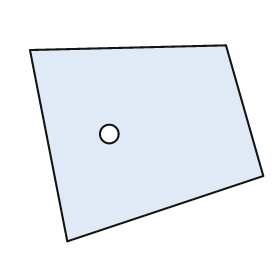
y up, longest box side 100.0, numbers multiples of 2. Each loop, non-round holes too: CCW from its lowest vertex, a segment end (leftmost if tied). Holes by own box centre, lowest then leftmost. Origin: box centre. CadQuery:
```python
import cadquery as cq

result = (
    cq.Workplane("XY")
    .moveTo(-34.0, -42.0)
    .lineTo(50.0, -14.0)
    .lineTo(34.0, 42.0)
    .lineTo(-50.0, 40.0)
    .close()
    .moveTo(-16.0, 4.0)
    .circle(4.0)
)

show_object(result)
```